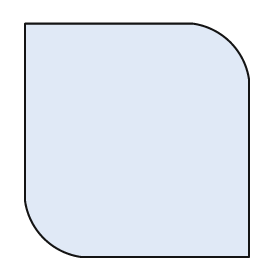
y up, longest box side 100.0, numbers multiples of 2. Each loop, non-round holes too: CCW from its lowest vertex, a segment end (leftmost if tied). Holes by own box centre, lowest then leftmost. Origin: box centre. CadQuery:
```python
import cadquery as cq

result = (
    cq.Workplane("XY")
    .moveTo(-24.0, -50.0)
    .lineTo(48.0, -50.0)
    .lineTo(48.0, 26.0)
    .threePointArc((40.0, 42.0), (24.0, 50.0))
    .lineTo(-48.0, 50.0)
    .lineTo(-48.0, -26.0)
    .threePointArc((-40.0, -42.0), (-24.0, -50.0))
    .close()
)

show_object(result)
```